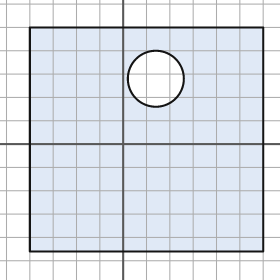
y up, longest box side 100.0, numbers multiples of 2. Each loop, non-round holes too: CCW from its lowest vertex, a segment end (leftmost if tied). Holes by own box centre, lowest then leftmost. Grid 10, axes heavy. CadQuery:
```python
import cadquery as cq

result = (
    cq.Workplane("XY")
    .moveTo(-40.0, -46.0)
    .lineTo(60.0, -46.0)
    .lineTo(60.0, 50.0)
    .lineTo(-40.0, 50.0)
    .close()
    .moveTo(14.0, 28.0)
    .circle(12.0)
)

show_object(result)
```